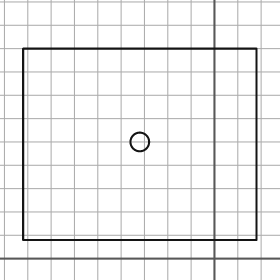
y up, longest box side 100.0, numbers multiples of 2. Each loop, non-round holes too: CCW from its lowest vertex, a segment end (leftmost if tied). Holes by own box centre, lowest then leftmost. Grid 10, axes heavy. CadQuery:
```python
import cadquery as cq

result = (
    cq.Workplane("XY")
    .moveTo(-82.0, 8.0)
    .lineTo(18.0, 8.0)
    .lineTo(18.0, 90.0)
    .lineTo(-82.0, 90.0)
    .close()
    .moveTo(-32.0, 50.0)
    .circle(4.0)
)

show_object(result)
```